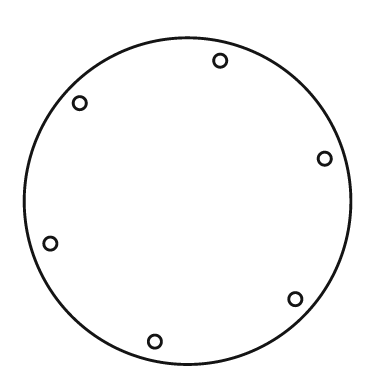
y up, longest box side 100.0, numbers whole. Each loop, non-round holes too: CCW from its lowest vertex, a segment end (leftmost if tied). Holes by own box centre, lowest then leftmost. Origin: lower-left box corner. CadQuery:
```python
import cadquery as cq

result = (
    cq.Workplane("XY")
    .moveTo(50.0, 50.0)
    .circle(50.0)
    .moveTo(40.0, 7.0)
    .circle(2.0)
    .moveTo(83.0, 20.0)
    .circle(2.0)
    .moveTo(8.0, 37.0)
    .circle(2.0)
    .moveTo(92.0, 63.0)
    .circle(2.0)
    .moveTo(17.0, 80.0)
    .circle(2.0)
    .moveTo(60.0, 93.0)
    .circle(2.0)
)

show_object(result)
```